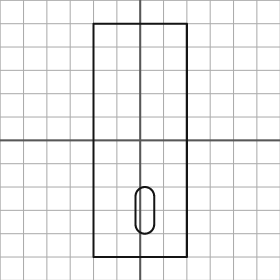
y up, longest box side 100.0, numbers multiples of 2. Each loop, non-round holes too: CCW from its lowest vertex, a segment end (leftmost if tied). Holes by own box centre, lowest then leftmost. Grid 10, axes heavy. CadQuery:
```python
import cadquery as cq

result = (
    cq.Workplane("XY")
    .moveTo(-20.0, -50.0)
    .lineTo(20.0, -50.0)
    .lineTo(20.0, 50.0)
    .lineTo(-20.0, 50.0)
    .close()
    .moveTo(-2.0, -36.0)
    .threePointArc((2.0, -40.0), (6.0, -36.0))
    .lineTo(6.0, -24.0)
    .threePointArc((2.0, -20.0), (-2.0, -24.0))
    .close()
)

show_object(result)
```